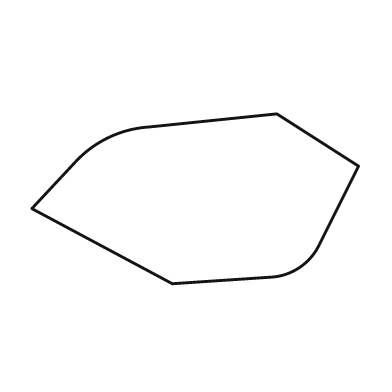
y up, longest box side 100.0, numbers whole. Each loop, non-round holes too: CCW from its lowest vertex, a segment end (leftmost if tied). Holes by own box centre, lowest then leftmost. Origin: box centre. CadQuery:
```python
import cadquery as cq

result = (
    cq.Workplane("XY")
    .moveTo(-7.0, -26.0)
    .lineTo(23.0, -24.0)
    .threePointArc((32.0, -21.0), (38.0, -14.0))
    .lineTo(50.0, 10.0)
    .lineTo(25.0, 26.0)
    .lineTo(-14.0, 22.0)
    .threePointArc((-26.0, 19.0), (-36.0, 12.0))
    .lineTo(-50.0, -3.0)
    .close()
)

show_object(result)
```